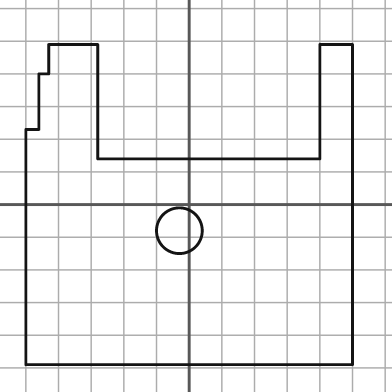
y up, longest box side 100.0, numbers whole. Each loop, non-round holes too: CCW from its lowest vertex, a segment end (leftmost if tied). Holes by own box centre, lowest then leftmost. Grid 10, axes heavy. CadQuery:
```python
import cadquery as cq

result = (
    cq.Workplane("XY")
    .moveTo(-50.0, -49.0)
    .lineTo(50.0, -49.0)
    .lineTo(50.0, 49.0)
    .lineTo(40.0, 49.0)
    .lineTo(40.0, 14.0)
    .lineTo(-28.0, 14.0)
    .lineTo(-28.0, 49.0)
    .lineTo(-43.0, 49.0)
    .lineTo(-43.0, 40.0)
    .lineTo(-46.0, 40.0)
    .lineTo(-46.0, 23.0)
    .lineTo(-50.0, 23.0)
    .close()
    .moveTo(-3.0, -8.0)
    .circle(7.0)
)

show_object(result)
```